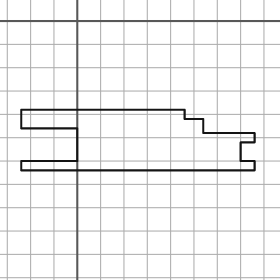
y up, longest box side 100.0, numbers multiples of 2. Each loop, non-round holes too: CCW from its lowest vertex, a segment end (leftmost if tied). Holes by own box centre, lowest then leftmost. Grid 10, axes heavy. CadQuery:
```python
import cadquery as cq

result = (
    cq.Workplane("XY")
    .moveTo(-24.0, -64.0)
    .lineTo(76.0, -64.0)
    .lineTo(76.0, -60.0)
    .lineTo(70.0, -60.0)
    .lineTo(70.0, -52.0)
    .lineTo(76.0, -52.0)
    .lineTo(76.0, -48.0)
    .lineTo(54.0, -48.0)
    .lineTo(54.0, -42.0)
    .lineTo(46.0, -42.0)
    .lineTo(46.0, -38.0)
    .lineTo(-24.0, -38.0)
    .lineTo(-24.0, -46.0)
    .lineTo(0.0, -46.0)
    .lineTo(0.0, -60.0)
    .lineTo(-24.0, -60.0)
    .close()
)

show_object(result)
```